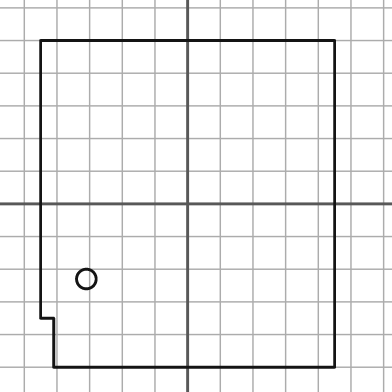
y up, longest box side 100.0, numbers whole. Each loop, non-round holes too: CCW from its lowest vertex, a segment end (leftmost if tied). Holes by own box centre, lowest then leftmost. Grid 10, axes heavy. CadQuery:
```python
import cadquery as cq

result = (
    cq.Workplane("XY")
    .moveTo(-41.0, -50.0)
    .lineTo(45.0, -50.0)
    .lineTo(45.0, 50.0)
    .lineTo(-45.0, 50.0)
    .lineTo(-45.0, -35.0)
    .lineTo(-41.0, -35.0)
    .close()
    .moveTo(-31.0, -23.0)
    .circle(3.0)
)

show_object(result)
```